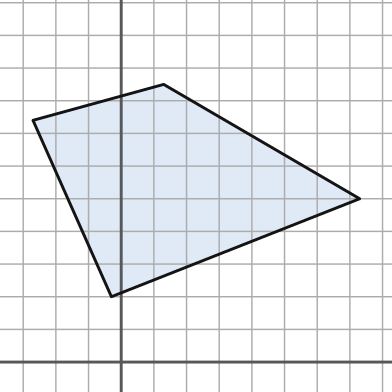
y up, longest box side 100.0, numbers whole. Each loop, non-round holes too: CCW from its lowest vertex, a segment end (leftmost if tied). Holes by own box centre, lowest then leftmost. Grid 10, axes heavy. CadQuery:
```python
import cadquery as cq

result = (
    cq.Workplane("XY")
    .moveTo(-3.0, 20.0)
    .lineTo(73.0, 50.0)
    .lineTo(13.0, 85.0)
    .lineTo(-27.0, 74.0)
    .close()
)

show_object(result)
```